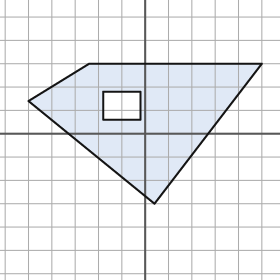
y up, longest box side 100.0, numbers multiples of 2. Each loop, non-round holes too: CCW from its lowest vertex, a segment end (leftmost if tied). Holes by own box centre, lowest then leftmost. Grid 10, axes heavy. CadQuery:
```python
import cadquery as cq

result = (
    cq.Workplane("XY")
    .moveTo(4.0, -30.0)
    .lineTo(50.0, 30.0)
    .lineTo(-24.0, 30.0)
    .lineTo(-50.0, 14.0)
    .close()
    .moveTo(-18.0, 6.0)
    .lineTo(-2.0, 6.0)
    .lineTo(-2.0, 18.0)
    .lineTo(-18.0, 18.0)
    .close()
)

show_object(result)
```